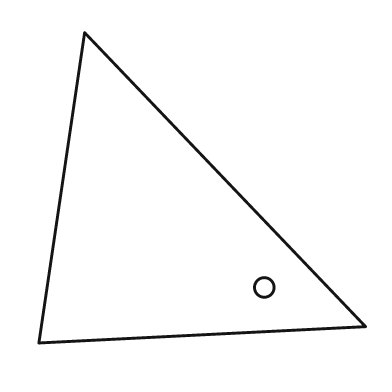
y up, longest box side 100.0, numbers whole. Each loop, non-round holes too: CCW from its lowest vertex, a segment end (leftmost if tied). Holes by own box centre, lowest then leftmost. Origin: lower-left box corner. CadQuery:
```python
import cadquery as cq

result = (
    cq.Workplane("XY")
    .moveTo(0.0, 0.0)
    .lineTo(100.0, 5.0)
    .lineTo(14.0, 95.0)
    .close()
    .moveTo(69.0, 17.0)
    .circle(3.0)
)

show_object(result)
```